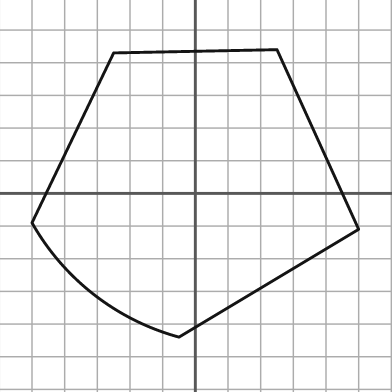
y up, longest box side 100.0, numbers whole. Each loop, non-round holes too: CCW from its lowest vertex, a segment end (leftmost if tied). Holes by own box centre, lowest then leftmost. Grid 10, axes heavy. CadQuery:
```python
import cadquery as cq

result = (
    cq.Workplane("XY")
    .moveTo(-5.0, -44.0)
    .lineTo(50.0, -11.0)
    .lineTo(25.0, 44.0)
    .lineTo(-25.0, 43.0)
    .lineTo(-50.0, -9.0)
    .threePointArc((-31.0, -31.0), (-5.0, -44.0))
    .close()
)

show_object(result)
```